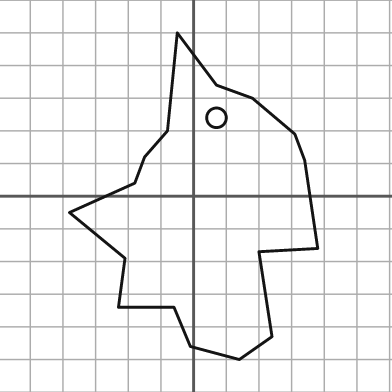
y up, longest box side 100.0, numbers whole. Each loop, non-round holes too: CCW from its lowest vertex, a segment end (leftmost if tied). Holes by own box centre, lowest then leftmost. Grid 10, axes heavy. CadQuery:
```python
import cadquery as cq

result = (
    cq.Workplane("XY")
    .moveTo(14.0, -50.0)
    .lineTo(24.0, -43.0)
    .lineTo(20.0, -17.0)
    .lineTo(38.0, -16.0)
    .lineTo(34.0, 11.0)
    .lineTo(31.0, 19.0)
    .lineTo(18.0, 30.0)
    .lineTo(7.0, 34.0)
    .lineTo(-5.0, 50.0)
    .lineTo(-8.0, 20.0)
    .lineTo(-15.0, 12.0)
    .lineTo(-18.0, 4.0)
    .lineTo(-38.0, -5.0)
    .lineTo(-21.0, -19.0)
    .lineTo(-23.0, -34.0)
    .lineTo(-6.0, -34.0)
    .lineTo(-1.0, -46.0)
    .close()
    .moveTo(7.0, 24.0)
    .circle(3.0)
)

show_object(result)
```